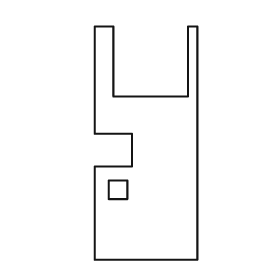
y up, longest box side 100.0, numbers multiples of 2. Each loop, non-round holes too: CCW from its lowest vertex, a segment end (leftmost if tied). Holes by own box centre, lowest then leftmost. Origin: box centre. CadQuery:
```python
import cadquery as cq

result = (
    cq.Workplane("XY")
    .moveTo(-22.0, -50.0)
    .lineTo(22.0, -50.0)
    .lineTo(22.0, 50.0)
    .lineTo(18.0, 50.0)
    .lineTo(18.0, 20.0)
    .lineTo(-14.0, 20.0)
    .lineTo(-14.0, 50.0)
    .lineTo(-22.0, 50.0)
    .lineTo(-22.0, 4.0)
    .lineTo(-6.0, 4.0)
    .lineTo(-6.0, -10.0)
    .lineTo(-22.0, -10.0)
    .close()
    .moveTo(-16.0, -24.0)
    .lineTo(-8.0, -24.0)
    .lineTo(-8.0, -16.0)
    .lineTo(-16.0, -16.0)
    .close()
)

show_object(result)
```